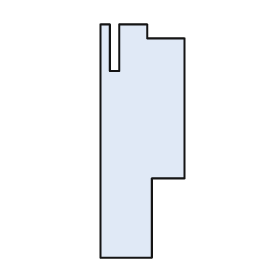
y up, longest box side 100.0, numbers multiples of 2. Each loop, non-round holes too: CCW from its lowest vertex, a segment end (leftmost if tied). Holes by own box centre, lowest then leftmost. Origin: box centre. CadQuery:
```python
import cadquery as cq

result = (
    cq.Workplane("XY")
    .moveTo(-18.0, -50.0)
    .lineTo(4.0, -50.0)
    .lineTo(4.0, -16.0)
    .lineTo(18.0, -16.0)
    .lineTo(18.0, 44.0)
    .lineTo(2.0, 44.0)
    .lineTo(2.0, 50.0)
    .lineTo(-10.0, 50.0)
    .lineTo(-10.0, 30.0)
    .lineTo(-14.0, 30.0)
    .lineTo(-14.0, 50.0)
    .lineTo(-18.0, 50.0)
    .close()
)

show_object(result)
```